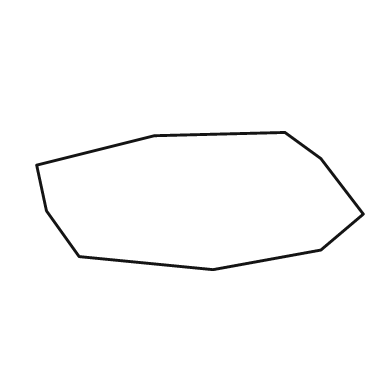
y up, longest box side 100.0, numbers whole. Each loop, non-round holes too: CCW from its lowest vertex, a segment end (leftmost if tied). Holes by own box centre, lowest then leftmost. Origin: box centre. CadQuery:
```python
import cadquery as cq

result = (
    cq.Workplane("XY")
    .moveTo(4.0, -21.0)
    .lineTo(37.0, -15.0)
    .lineTo(50.0, -4.0)
    .lineTo(37.0, 13.0)
    .lineTo(26.0, 21.0)
    .lineTo(-14.0, 20.0)
    .lineTo(-50.0, 11.0)
    .lineTo(-47.0, -3.0)
    .lineTo(-37.0, -17.0)
    .close()
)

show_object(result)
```